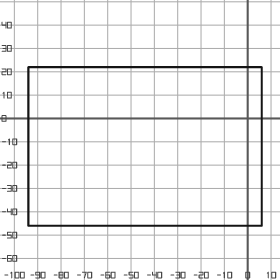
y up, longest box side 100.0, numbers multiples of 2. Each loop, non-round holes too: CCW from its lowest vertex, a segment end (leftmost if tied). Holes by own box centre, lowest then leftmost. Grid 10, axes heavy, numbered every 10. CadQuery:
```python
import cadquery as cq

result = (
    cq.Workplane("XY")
    .moveTo(-94.0, -46.0)
    .lineTo(6.0, -46.0)
    .lineTo(6.0, 22.0)
    .lineTo(-94.0, 22.0)
    .close()
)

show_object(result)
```